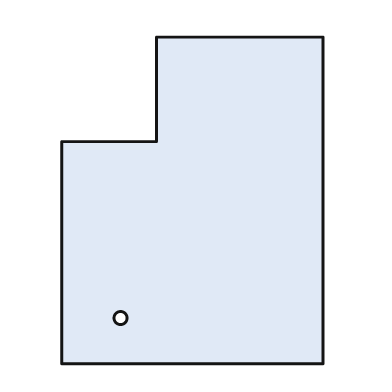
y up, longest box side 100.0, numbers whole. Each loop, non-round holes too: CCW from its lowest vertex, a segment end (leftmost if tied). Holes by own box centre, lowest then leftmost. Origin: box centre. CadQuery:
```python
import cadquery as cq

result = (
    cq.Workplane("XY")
    .moveTo(-40.0, -50.0)
    .lineTo(40.0, -50.0)
    .lineTo(40.0, 50.0)
    .lineTo(-11.0, 50.0)
    .lineTo(-11.0, 18.0)
    .lineTo(-40.0, 18.0)
    .close()
    .moveTo(-22.0, -36.0)
    .circle(2.0)
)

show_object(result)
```